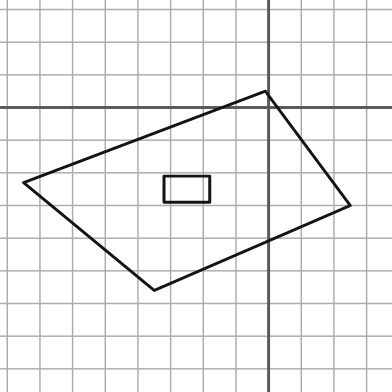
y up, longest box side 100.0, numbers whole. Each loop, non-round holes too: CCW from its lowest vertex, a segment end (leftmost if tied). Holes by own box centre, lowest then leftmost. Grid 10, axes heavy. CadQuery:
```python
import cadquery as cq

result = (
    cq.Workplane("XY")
    .moveTo(-35.0, -56.0)
    .lineTo(25.0, -30.0)
    .lineTo(-1.0, 5.0)
    .lineTo(-75.0, -23.0)
    .close()
    .moveTo(-32.0, -29.0)
    .lineTo(-18.0, -29.0)
    .lineTo(-18.0, -21.0)
    .lineTo(-32.0, -21.0)
    .close()
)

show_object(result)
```